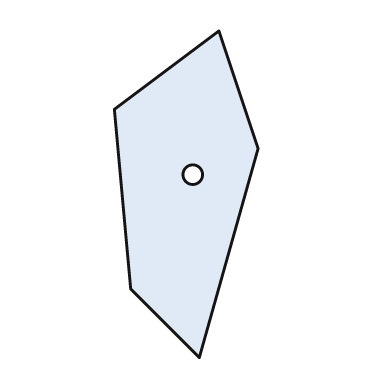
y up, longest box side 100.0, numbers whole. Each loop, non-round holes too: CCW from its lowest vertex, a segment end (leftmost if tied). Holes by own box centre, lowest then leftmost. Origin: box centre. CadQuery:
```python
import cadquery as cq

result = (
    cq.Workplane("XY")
    .moveTo(4.0, -50.0)
    .lineTo(22.0, 14.0)
    .lineTo(10.0, 50.0)
    .lineTo(-22.0, 26.0)
    .lineTo(-17.0, -29.0)
    .close()
    .moveTo(2.0, 6.0)
    .circle(3.0)
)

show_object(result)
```